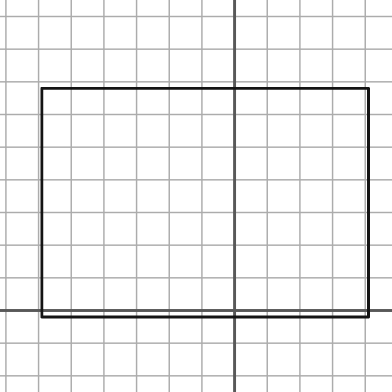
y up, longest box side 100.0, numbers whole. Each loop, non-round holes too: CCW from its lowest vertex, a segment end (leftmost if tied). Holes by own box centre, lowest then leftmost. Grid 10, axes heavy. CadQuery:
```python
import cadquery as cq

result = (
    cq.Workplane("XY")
    .moveTo(-59.0, -2.0)
    .lineTo(41.0, -2.0)
    .lineTo(41.0, 68.0)
    .lineTo(-59.0, 68.0)
    .close()
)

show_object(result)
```